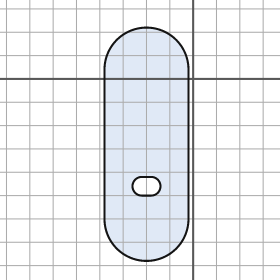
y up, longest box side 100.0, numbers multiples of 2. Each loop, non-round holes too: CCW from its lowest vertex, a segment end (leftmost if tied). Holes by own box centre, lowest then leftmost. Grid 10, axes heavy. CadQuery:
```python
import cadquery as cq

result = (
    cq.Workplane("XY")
    .moveTo(-38.0, -60.0)
    .threePointArc((-20.0, -78.0), (-2.0, -60.0))
    .lineTo(-2.0, 4.0)
    .threePointArc((-20.0, 22.0), (-38.0, 4.0))
    .close()
    .moveTo(-22.0, -50.0)
    .lineTo(-18.0, -50.0)
    .threePointArc((-14.0, -46.0), (-18.0, -42.0))
    .lineTo(-22.0, -42.0)
    .threePointArc((-26.0, -46.0), (-22.0, -50.0))
    .close()
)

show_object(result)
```